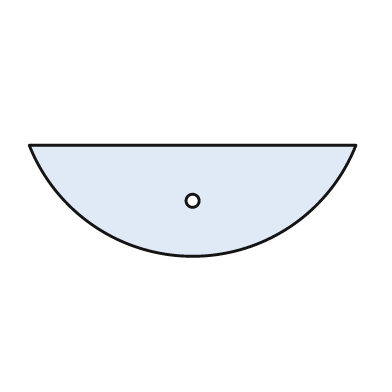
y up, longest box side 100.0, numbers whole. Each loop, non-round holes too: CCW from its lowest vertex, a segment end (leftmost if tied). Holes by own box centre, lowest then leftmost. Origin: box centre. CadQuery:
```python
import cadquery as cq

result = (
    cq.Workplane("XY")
    .moveTo(-50.0, 17.0)
    .threePointArc((0.0, -17.0), (50.0, 17.0))
    .close()
    .moveTo(0.0, 0.0)
    .circle(2.0)
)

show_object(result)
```